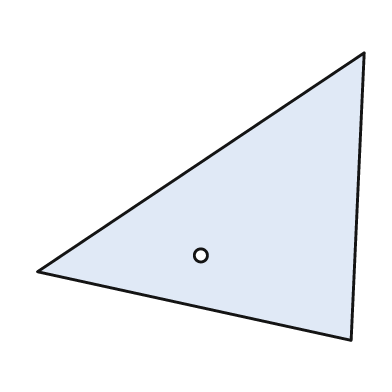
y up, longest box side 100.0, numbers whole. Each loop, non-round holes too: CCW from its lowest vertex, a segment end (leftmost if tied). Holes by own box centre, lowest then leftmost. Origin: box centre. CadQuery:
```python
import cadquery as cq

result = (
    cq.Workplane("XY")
    .moveTo(46.0, -44.0)
    .lineTo(50.0, 44.0)
    .lineTo(-50.0, -23.0)
    .close()
    .moveTo(0.0, -18.0)
    .circle(2.0)
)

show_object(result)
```